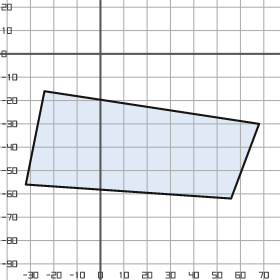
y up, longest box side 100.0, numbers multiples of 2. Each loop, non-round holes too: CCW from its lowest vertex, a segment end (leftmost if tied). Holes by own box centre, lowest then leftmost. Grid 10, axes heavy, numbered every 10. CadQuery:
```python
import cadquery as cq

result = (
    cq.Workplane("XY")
    .moveTo(56.0, -62.0)
    .lineTo(68.0, -30.0)
    .lineTo(-24.0, -16.0)
    .lineTo(-32.0, -56.0)
    .close()
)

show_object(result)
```